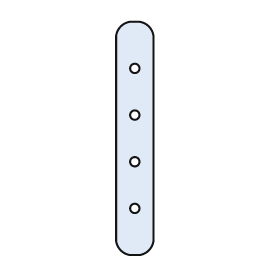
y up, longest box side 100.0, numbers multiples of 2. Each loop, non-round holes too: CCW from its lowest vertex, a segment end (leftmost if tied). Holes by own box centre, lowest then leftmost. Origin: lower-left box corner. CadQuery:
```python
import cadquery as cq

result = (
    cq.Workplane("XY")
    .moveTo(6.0, 0.0)
    .lineTo(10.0, 0.0)
    .threePointArc((14.0, 2.0), (16.0, 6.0))
    .lineTo(16.0, 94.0)
    .threePointArc((14.0, 98.0), (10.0, 100.0))
    .lineTo(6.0, 100.0)
    .threePointArc((2.0, 98.0), (0.0, 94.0))
    .lineTo(0.0, 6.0)
    .threePointArc((2.0, 2.0), (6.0, 0.0))
    .close()
    .moveTo(8.0, 20.0)
    .circle(2.0)
    .moveTo(8.0, 40.0)
    .circle(2.0)
    .moveTo(8.0, 60.0)
    .circle(2.0)
    .moveTo(8.0, 80.0)
    .circle(2.0)
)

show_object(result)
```